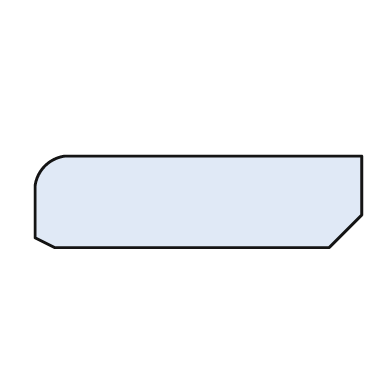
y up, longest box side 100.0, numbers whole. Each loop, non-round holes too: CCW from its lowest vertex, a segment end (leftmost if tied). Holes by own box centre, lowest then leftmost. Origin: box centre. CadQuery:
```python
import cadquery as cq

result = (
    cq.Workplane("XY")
    .moveTo(-44.0, -14.0)
    .lineTo(40.0, -14.0)
    .lineTo(50.0, -4.0)
    .lineTo(50.0, 14.0)
    .lineTo(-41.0, 14.0)
    .threePointArc((-47.0, 11.0), (-50.0, 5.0))
    .lineTo(-50.0, -11.0)
    .close()
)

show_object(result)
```